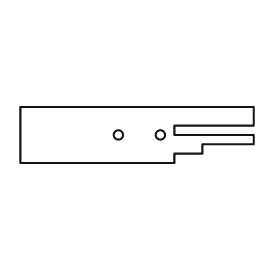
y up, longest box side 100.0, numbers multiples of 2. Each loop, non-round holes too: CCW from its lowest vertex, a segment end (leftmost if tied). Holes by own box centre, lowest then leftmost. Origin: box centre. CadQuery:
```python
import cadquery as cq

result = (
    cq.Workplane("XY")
    .moveTo(-50.0, -12.0)
    .lineTo(16.0, -12.0)
    .lineTo(16.0, -8.0)
    .lineTo(28.0, -8.0)
    .lineTo(28.0, -4.0)
    .lineTo(50.0, -4.0)
    .lineTo(50.0, 0.0)
    .lineTo(16.0, 0.0)
    .lineTo(16.0, 4.0)
    .lineTo(50.0, 4.0)
    .lineTo(50.0, 12.0)
    .lineTo(-50.0, 12.0)
    .close()
    .moveTo(-8.0, 0.0)
    .circle(2.0)
    .moveTo(10.0, 0.0)
    .circle(2.0)
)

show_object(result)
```